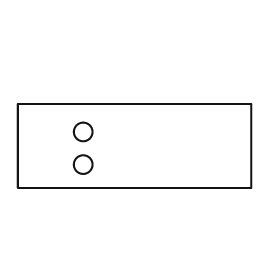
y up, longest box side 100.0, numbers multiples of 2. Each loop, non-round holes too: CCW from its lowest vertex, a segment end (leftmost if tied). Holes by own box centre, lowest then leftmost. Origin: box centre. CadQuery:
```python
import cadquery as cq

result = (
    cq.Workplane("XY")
    .moveTo(-50.0, -18.0)
    .lineTo(50.0, -18.0)
    .lineTo(50.0, 18.0)
    .lineTo(-50.0, 18.0)
    .close()
    .moveTo(-22.0, -8.0)
    .circle(4.0)
    .moveTo(-22.0, 6.0)
    .circle(4.0)
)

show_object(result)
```